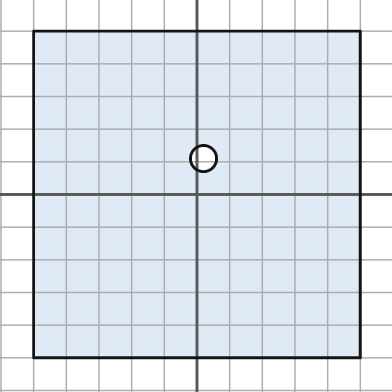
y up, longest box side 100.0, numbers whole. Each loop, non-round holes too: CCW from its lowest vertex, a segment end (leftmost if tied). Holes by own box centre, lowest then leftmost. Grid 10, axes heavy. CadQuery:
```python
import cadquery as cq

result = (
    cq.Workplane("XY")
    .moveTo(-50.0, -50.0)
    .lineTo(50.0, -50.0)
    .lineTo(50.0, 50.0)
    .lineTo(-50.0, 50.0)
    .close()
    .moveTo(2.0, 11.0)
    .circle(4.0)
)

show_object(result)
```